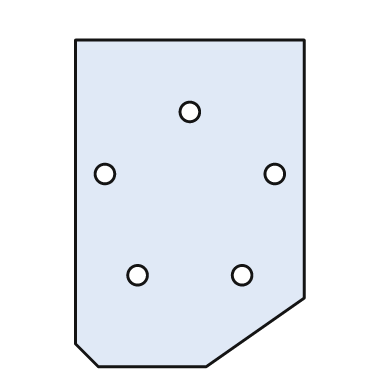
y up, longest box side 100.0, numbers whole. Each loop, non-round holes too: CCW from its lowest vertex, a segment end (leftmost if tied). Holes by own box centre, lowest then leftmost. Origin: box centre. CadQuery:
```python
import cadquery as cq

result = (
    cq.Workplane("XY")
    .moveTo(-28.0, -50.0)
    .lineTo(5.0, -50.0)
    .lineTo(35.0, -29.0)
    .lineTo(35.0, 50.0)
    .lineTo(-35.0, 50.0)
    .lineTo(-35.0, -43.0)
    .close()
    .moveTo(-16.0, -22.0)
    .circle(3.0)
    .moveTo(16.0, -22.0)
    .circle(3.0)
    .moveTo(-26.0, 9.0)
    .circle(3.0)
    .moveTo(26.0, 9.0)
    .circle(3.0)
    .moveTo(0.0, 28.0)
    .circle(3.0)
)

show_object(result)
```